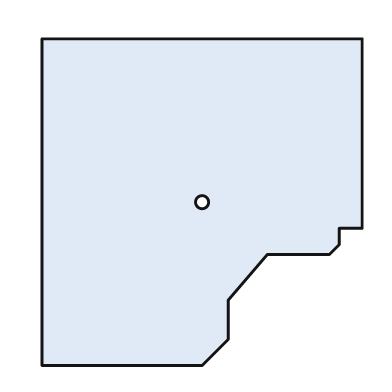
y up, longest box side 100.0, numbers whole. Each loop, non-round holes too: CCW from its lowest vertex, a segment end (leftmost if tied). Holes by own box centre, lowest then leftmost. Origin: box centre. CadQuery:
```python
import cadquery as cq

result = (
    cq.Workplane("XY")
    .moveTo(-49.0, -50.0)
    .lineTo(0.0, -50.0)
    .lineTo(8.0, -42.0)
    .lineTo(8.0, -30.0)
    .lineTo(20.0, -16.0)
    .lineTo(39.0, -16.0)
    .lineTo(42.0, -13.0)
    .lineTo(42.0, -8.0)
    .lineTo(49.0, -8.0)
    .lineTo(49.0, 50.0)
    .lineTo(-49.0, 50.0)
    .close()
    .moveTo(0.0, 0.0)
    .circle(2.0)
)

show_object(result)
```